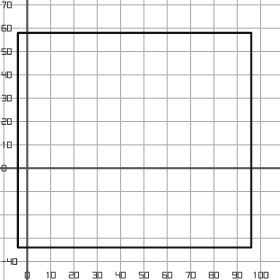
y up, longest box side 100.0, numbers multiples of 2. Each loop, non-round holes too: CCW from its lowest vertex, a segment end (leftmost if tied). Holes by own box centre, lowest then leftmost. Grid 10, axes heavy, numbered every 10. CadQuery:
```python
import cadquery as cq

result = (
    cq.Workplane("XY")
    .moveTo(-4.0, -34.0)
    .lineTo(96.0, -34.0)
    .lineTo(96.0, 58.0)
    .lineTo(-4.0, 58.0)
    .close()
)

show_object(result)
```